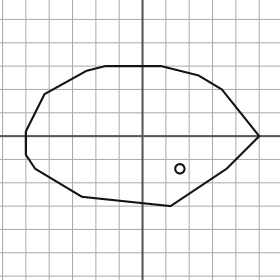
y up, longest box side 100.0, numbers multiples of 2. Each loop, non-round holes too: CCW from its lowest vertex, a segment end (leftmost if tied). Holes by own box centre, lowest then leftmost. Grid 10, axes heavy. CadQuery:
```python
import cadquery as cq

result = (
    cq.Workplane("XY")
    .moveTo(12.0, -30.0)
    .lineTo(36.0, -14.0)
    .lineTo(50.0, 0.0)
    .lineTo(34.0, 20.0)
    .lineTo(24.0, 26.0)
    .lineTo(8.0, 30.0)
    .lineTo(-16.0, 30.0)
    .lineTo(-24.0, 28.0)
    .lineTo(-42.0, 18.0)
    .lineTo(-50.0, 2.0)
    .lineTo(-50.0, -8.0)
    .lineTo(-46.0, -14.0)
    .lineTo(-26.0, -26.0)
    .close()
    .moveTo(16.0, -14.0)
    .circle(2.0)
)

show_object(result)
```